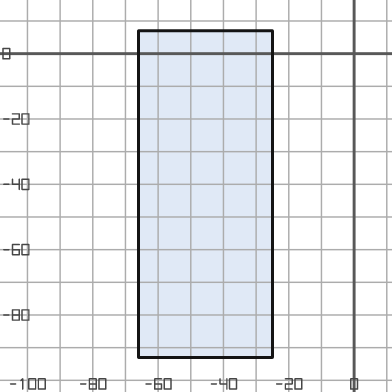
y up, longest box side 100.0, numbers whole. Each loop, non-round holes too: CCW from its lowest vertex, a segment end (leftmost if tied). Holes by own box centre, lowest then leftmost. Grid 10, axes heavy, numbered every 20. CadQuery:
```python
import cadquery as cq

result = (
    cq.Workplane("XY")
    .moveTo(-66.0, -93.0)
    .lineTo(-25.0, -93.0)
    .lineTo(-25.0, 7.0)
    .lineTo(-66.0, 7.0)
    .close()
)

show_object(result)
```